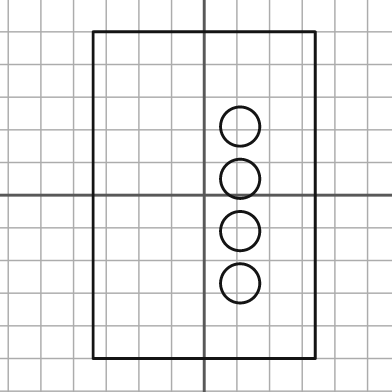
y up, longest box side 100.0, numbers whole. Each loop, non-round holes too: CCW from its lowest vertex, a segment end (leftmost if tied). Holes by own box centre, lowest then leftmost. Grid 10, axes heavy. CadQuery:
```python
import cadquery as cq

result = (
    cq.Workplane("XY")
    .moveTo(-34.0, -50.0)
    .lineTo(34.0, -50.0)
    .lineTo(34.0, 50.0)
    .lineTo(-34.0, 50.0)
    .close()
    .moveTo(11.0, -27.0)
    .circle(6.0)
    .moveTo(11.0, -11.0)
    .circle(6.0)
    .moveTo(11.0, 5.0)
    .circle(6.0)
    .moveTo(11.0, 21.0)
    .circle(6.0)
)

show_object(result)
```